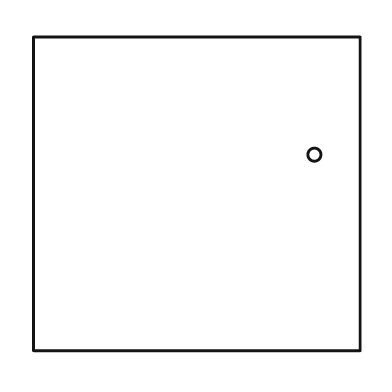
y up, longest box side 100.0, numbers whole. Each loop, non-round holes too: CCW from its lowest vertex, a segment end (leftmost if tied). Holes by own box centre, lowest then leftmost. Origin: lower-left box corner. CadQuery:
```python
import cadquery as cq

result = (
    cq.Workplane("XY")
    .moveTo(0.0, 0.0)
    .lineTo(100.0, 0.0)
    .lineTo(100.0, 96.0)
    .lineTo(0.0, 96.0)
    .close()
    .moveTo(86.0, 60.0)
    .circle(2.0)
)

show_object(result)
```